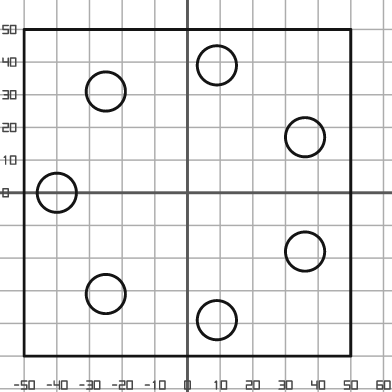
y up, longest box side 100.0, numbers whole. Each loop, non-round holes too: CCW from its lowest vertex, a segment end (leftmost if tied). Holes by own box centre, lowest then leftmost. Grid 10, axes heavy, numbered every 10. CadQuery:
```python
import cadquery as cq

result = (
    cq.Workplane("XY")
    .moveTo(-50.0, -50.0)
    .lineTo(50.0, -50.0)
    .lineTo(50.0, 50.0)
    .lineTo(-50.0, 50.0)
    .close()
    .moveTo(9.0, -39.0)
    .circle(6.0)
    .moveTo(-25.0, -31.0)
    .circle(6.0)
    .moveTo(36.0, -18.0)
    .circle(6.0)
    .moveTo(-40.0, 0.0)
    .circle(6.0)
    .moveTo(36.0, 17.0)
    .circle(6.0)
    .moveTo(-25.0, 31.0)
    .circle(6.0)
    .moveTo(9.0, 39.0)
    .circle(6.0)
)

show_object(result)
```